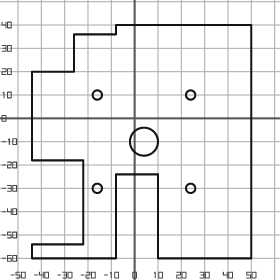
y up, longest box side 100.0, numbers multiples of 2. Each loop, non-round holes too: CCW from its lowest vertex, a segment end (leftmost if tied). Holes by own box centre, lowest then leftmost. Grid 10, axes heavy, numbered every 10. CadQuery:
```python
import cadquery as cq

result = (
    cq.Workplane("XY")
    .moveTo(-44.0, -60.0)
    .lineTo(-8.0, -60.0)
    .lineTo(-8.0, -24.0)
    .lineTo(10.0, -24.0)
    .lineTo(10.0, -60.0)
    .lineTo(50.0, -60.0)
    .lineTo(50.0, 40.0)
    .lineTo(-8.0, 40.0)
    .lineTo(-8.0, 36.0)
    .lineTo(-26.0, 36.0)
    .lineTo(-26.0, 20.0)
    .lineTo(-44.0, 20.0)
    .lineTo(-44.0, -18.0)
    .lineTo(-22.0, -18.0)
    .lineTo(-22.0, -54.0)
    .lineTo(-44.0, -54.0)
    .close()
    .moveTo(-16.0, -30.0)
    .circle(2.0)
    .moveTo(24.0, -30.0)
    .circle(2.0)
    .moveTo(4.0, -10.0)
    .circle(6.0)
    .moveTo(-16.0, 10.0)
    .circle(2.0)
    .moveTo(24.0, 10.0)
    .circle(2.0)
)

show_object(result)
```